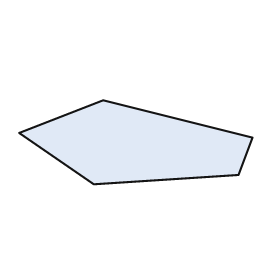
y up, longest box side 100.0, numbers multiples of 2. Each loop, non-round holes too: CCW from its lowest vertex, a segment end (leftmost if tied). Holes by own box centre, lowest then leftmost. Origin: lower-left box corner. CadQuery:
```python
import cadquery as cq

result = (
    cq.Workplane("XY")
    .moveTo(32.0, 0.0)
    .lineTo(94.0, 4.0)
    .lineTo(100.0, 20.0)
    .lineTo(36.0, 36.0)
    .lineTo(0.0, 22.0)
    .close()
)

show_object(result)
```